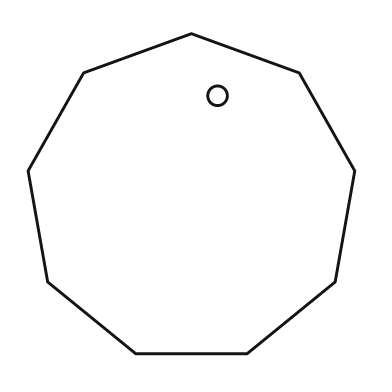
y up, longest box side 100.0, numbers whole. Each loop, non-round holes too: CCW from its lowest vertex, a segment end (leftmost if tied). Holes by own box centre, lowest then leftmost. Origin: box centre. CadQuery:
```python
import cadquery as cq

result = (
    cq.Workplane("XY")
    .moveTo(-17.0, -49.0)
    .lineTo(17.0, -49.0)
    .lineTo(44.0, -27.0)
    .lineTo(50.0, 7.0)
    .lineTo(33.0, 37.0)
    .lineTo(0.0, 49.0)
    .lineTo(-33.0, 37.0)
    .lineTo(-50.0, 7.0)
    .lineTo(-44.0, -27.0)
    .close()
    .moveTo(8.0, 30.0)
    .circle(3.0)
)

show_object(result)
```